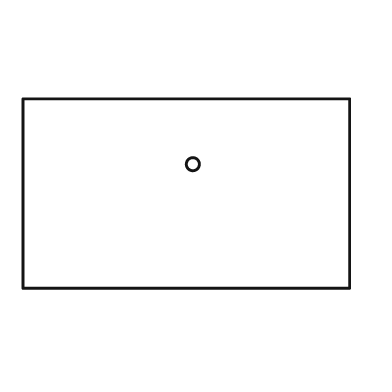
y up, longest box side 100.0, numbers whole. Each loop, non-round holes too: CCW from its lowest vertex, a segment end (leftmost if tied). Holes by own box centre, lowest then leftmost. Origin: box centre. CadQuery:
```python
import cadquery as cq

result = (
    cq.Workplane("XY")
    .moveTo(-50.0, -29.0)
    .lineTo(50.0, -29.0)
    .lineTo(50.0, 29.0)
    .lineTo(-50.0, 29.0)
    .close()
    .moveTo(2.0, 9.0)
    .circle(2.0)
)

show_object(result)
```